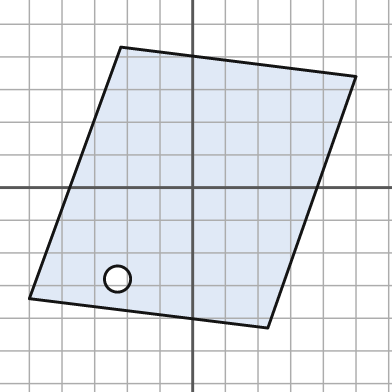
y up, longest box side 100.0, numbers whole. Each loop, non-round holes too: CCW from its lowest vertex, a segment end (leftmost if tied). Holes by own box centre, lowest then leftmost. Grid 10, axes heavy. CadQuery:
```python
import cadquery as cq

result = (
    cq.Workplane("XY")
    .moveTo(23.0, -43.0)
    .lineTo(50.0, 34.0)
    .lineTo(-22.0, 43.0)
    .lineTo(-50.0, -34.0)
    .close()
    .moveTo(-23.0, -28.0)
    .circle(4.0)
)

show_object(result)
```